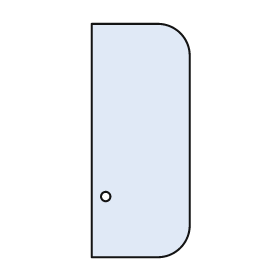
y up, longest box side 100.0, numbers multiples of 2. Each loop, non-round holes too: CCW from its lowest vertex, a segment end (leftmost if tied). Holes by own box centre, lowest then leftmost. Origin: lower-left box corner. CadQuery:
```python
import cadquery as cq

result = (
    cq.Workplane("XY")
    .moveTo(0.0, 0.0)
    .lineTo(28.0, 0.0)
    .threePointArc((38.0, 4.0), (42.0, 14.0))
    .lineTo(42.0, 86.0)
    .threePointArc((38.0, 96.0), (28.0, 100.0))
    .lineTo(0.0, 100.0)
    .close()
    .moveTo(6.0, 26.0)
    .circle(2.0)
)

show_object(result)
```